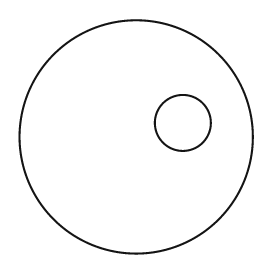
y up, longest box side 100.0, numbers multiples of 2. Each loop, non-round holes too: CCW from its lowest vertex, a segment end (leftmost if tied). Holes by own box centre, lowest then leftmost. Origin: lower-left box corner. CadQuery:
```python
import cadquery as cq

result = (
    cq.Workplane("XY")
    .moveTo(50.0, 50.0)
    .circle(50.0)
    .moveTo(70.0, 56.0)
    .circle(12.0)
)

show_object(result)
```